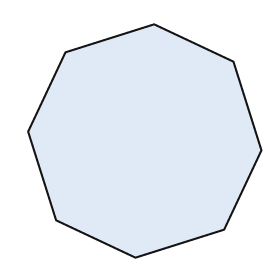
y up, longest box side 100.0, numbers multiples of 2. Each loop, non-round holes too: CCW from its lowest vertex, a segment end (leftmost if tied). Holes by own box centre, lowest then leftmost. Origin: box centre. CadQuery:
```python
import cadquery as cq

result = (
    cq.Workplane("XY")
    .moveTo(-4.0, -50.0)
    .lineTo(34.0, -38.0)
    .lineTo(50.0, -4.0)
    .lineTo(38.0, 34.0)
    .lineTo(4.0, 50.0)
    .lineTo(-34.0, 38.0)
    .lineTo(-50.0, 4.0)
    .lineTo(-38.0, -34.0)
    .close()
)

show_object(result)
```